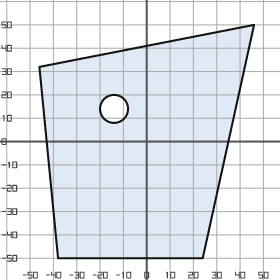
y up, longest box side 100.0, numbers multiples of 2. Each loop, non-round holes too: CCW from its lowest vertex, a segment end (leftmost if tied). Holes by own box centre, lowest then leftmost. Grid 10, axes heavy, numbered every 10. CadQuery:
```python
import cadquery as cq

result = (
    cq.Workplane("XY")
    .moveTo(-38.0, -50.0)
    .lineTo(24.0, -50.0)
    .lineTo(46.0, 50.0)
    .lineTo(-46.0, 32.0)
    .close()
    .moveTo(-14.0, 14.0)
    .circle(6.0)
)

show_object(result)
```